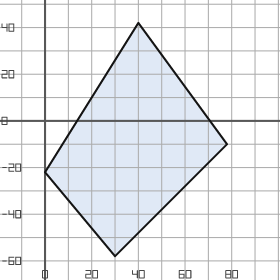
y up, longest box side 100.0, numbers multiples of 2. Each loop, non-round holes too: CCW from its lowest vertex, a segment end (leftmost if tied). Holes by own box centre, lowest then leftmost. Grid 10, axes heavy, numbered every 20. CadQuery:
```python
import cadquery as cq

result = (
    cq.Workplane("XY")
    .moveTo(30.0, -58.0)
    .lineTo(78.0, -10.0)
    .lineTo(40.0, 42.0)
    .lineTo(0.0, -22.0)
    .close()
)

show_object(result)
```